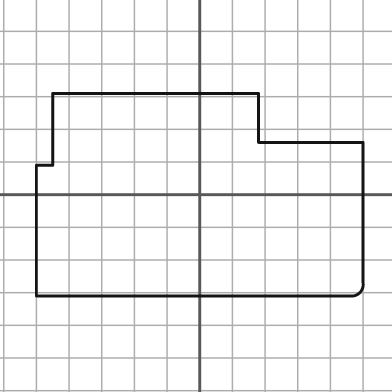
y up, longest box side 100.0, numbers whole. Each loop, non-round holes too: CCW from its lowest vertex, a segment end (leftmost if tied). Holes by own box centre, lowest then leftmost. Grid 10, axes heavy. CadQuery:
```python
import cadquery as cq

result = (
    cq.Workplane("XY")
    .moveTo(-50.0, -31.0)
    .lineTo(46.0, -31.0)
    .threePointArc((49.0, -30.0), (50.0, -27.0))
    .lineTo(50.0, 16.0)
    .lineTo(18.0, 16.0)
    .lineTo(18.0, 31.0)
    .lineTo(-45.0, 31.0)
    .lineTo(-45.0, 9.0)
    .lineTo(-50.0, 9.0)
    .close()
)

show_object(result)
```